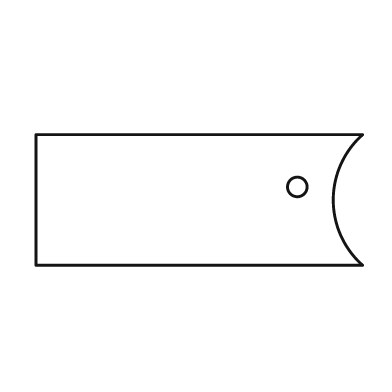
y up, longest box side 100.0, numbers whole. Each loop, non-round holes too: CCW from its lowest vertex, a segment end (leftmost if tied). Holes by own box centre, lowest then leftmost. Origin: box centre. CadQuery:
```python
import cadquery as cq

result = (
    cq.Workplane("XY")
    .moveTo(-50.0, -20.0)
    .lineTo(50.0, -20.0)
    .threePointArc((41.0, 0.0), (50.0, 20.0))
    .lineTo(-50.0, 20.0)
    .close()
    .moveTo(30.0, 4.0)
    .circle(3.0)
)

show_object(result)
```